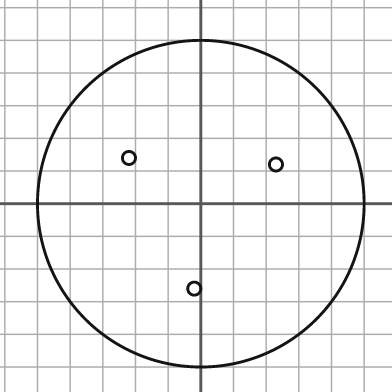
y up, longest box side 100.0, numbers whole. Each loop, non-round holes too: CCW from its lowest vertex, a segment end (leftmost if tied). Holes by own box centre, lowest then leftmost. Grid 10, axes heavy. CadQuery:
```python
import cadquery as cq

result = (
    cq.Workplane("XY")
    .moveTo(0.0, 0.0)
    .circle(50.0)
    .moveTo(-2.0, -26.0)
    .circle(2.0)
    .moveTo(23.0, 12.0)
    .circle(2.0)
    .moveTo(-22.0, 14.0)
    .circle(2.0)
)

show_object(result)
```